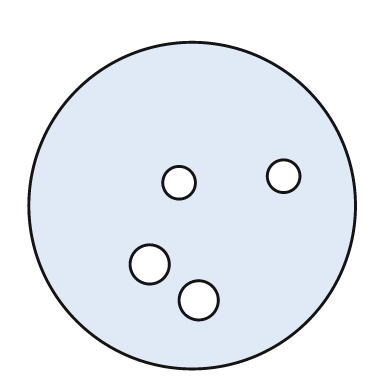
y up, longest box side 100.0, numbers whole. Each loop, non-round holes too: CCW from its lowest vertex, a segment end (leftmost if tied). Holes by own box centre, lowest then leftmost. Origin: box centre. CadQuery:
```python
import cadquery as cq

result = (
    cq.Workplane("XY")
    .moveTo(0.0, 0.0)
    .circle(50.0)
    .moveTo(2.0, -29.0)
    .circle(6.0)
    .moveTo(-13.0, -18.0)
    .circle(6.0)
    .moveTo(-4.0, 7.0)
    .circle(5.0)
    .moveTo(28.0, 9.0)
    .circle(5.0)
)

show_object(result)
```